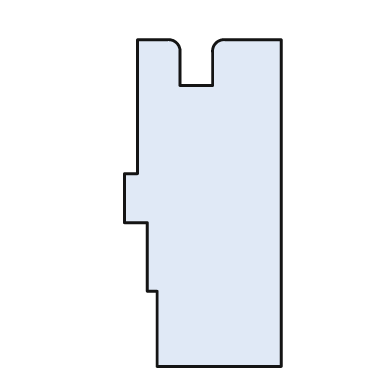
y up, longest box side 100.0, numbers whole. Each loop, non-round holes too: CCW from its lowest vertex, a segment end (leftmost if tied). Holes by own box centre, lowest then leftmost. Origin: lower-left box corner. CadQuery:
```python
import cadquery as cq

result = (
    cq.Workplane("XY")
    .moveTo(10.0, 0.0)
    .lineTo(48.0, 0.0)
    .lineTo(48.0, 100.0)
    .lineTo(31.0, 100.0)
    .threePointArc((28.0, 99.0), (27.0, 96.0))
    .lineTo(27.0, 86.0)
    .lineTo(17.0, 86.0)
    .lineTo(17.0, 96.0)
    .threePointArc((16.0, 99.0), (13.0, 100.0))
    .lineTo(4.0, 100.0)
    .lineTo(4.0, 59.0)
    .lineTo(0.0, 59.0)
    .lineTo(0.0, 44.0)
    .lineTo(7.0, 44.0)
    .lineTo(7.0, 23.0)
    .lineTo(10.0, 23.0)
    .close()
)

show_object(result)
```